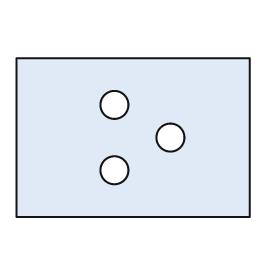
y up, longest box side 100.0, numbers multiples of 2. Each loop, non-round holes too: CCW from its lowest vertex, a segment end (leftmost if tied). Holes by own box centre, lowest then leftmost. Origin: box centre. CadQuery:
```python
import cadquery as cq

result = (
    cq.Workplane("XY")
    .moveTo(-50.0, -34.0)
    .lineTo(50.0, -34.0)
    .lineTo(50.0, 34.0)
    .lineTo(-50.0, 34.0)
    .close()
    .moveTo(-8.0, -14.0)
    .circle(6.0)
    .moveTo(16.0, 0.0)
    .circle(6.0)
    .moveTo(-8.0, 14.0)
    .circle(6.0)
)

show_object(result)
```